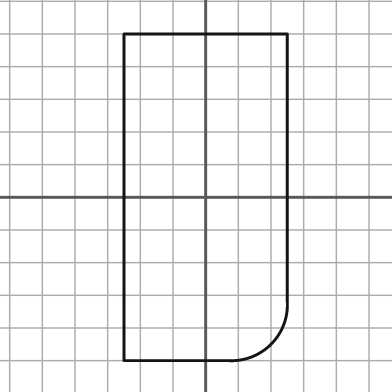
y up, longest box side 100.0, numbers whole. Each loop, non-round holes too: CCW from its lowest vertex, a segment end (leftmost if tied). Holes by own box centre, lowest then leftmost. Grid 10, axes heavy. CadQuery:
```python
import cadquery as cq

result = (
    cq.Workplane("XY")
    .moveTo(-25.0, -50.0)
    .lineTo(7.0, -50.0)
    .threePointArc((20.0, -45.0), (25.0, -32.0))
    .lineTo(25.0, 50.0)
    .lineTo(-25.0, 50.0)
    .close()
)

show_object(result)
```